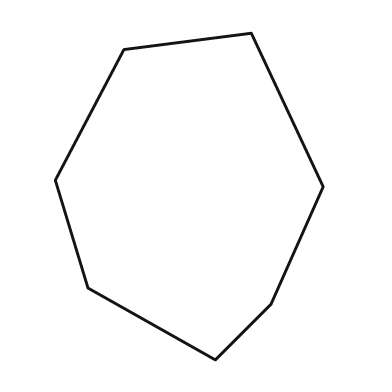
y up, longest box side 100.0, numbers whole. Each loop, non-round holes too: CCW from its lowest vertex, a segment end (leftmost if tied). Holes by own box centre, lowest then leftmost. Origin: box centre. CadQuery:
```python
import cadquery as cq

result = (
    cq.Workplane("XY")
    .moveTo(8.0, -50.0)
    .lineTo(25.0, -33.0)
    .lineTo(41.0, 3.0)
    .lineTo(19.0, 50.0)
    .lineTo(-20.0, 45.0)
    .lineTo(-41.0, 5.0)
    .lineTo(-31.0, -28.0)
    .close()
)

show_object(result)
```